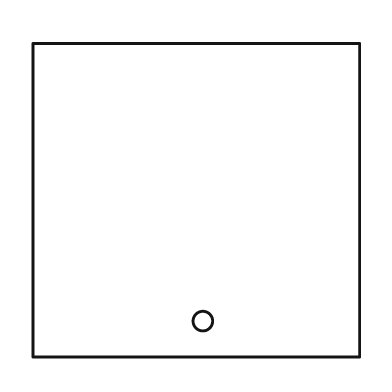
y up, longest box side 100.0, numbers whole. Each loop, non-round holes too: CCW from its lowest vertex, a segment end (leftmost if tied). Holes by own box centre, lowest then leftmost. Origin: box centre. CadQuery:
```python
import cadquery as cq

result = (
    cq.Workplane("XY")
    .moveTo(-50.0, -48.0)
    .lineTo(50.0, -48.0)
    .lineTo(50.0, 48.0)
    .lineTo(-50.0, 48.0)
    .close()
    .moveTo(2.0, -37.0)
    .circle(3.0)
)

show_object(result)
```